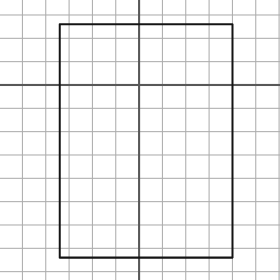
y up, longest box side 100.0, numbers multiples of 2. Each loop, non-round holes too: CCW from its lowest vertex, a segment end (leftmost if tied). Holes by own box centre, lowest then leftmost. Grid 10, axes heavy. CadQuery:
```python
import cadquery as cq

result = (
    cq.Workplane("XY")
    .moveTo(-34.0, -74.0)
    .lineTo(40.0, -74.0)
    .lineTo(40.0, 26.0)
    .lineTo(-34.0, 26.0)
    .close()
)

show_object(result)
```